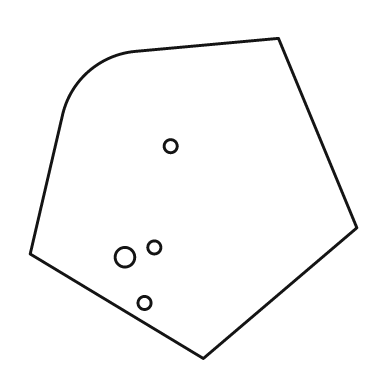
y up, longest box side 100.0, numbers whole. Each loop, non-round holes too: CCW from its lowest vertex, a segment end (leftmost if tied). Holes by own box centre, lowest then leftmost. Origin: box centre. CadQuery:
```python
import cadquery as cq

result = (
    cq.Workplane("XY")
    .moveTo(3.0, -49.0)
    .lineTo(50.0, -9.0)
    .lineTo(26.0, 49.0)
    .lineTo(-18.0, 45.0)
    .threePointArc((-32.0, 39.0), (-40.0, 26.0))
    .lineTo(-50.0, -17.0)
    .close()
    .moveTo(-15.0, -32.0)
    .circle(2.0)
    .moveTo(-21.0, -18.0)
    .circle(3.0)
    .moveTo(-12.0, -15.0)
    .circle(2.0)
    .moveTo(-7.0, 16.0)
    .circle(2.0)
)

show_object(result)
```